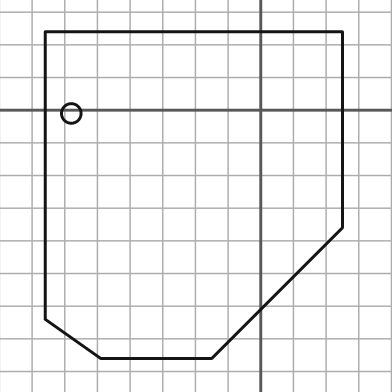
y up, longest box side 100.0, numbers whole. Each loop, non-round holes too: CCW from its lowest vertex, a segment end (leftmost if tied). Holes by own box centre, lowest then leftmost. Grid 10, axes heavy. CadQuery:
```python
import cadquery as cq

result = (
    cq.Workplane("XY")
    .moveTo(-49.0, -76.0)
    .lineTo(-15.0, -76.0)
    .lineTo(25.0, -36.0)
    .lineTo(25.0, 24.0)
    .lineTo(-66.0, 24.0)
    .lineTo(-66.0, -64.0)
    .close()
    .moveTo(-58.0, -1.0)
    .circle(3.0)
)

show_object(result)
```